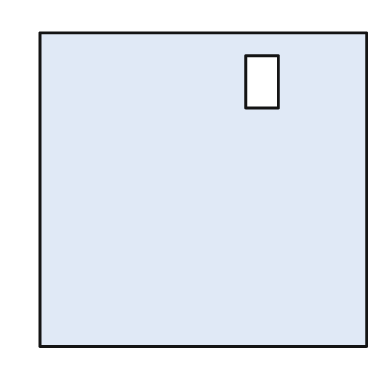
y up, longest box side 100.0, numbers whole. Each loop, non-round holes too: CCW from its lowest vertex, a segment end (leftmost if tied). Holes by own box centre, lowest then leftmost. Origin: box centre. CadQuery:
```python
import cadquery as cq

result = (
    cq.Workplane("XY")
    .moveTo(-50.0, -48.0)
    .lineTo(50.0, -48.0)
    .lineTo(50.0, 48.0)
    .lineTo(-50.0, 48.0)
    .close()
    .moveTo(13.0, 25.0)
    .lineTo(23.0, 25.0)
    .lineTo(23.0, 41.0)
    .lineTo(13.0, 41.0)
    .close()
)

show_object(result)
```